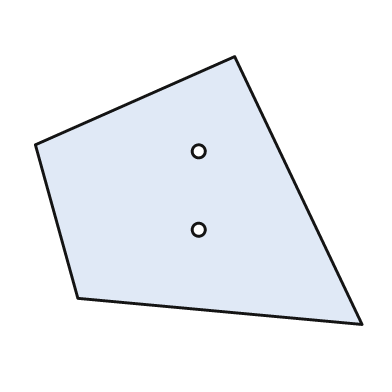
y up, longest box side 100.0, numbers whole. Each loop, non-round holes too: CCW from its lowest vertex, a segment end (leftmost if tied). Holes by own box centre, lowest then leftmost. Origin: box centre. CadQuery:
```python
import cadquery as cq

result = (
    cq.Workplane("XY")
    .moveTo(50.0, -41.0)
    .lineTo(11.0, 41.0)
    .lineTo(-50.0, 14.0)
    .lineTo(-37.0, -33.0)
    .close()
    .moveTo(0.0, -12.0)
    .circle(2.0)
    .moveTo(0.0, 12.0)
    .circle(2.0)
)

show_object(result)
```